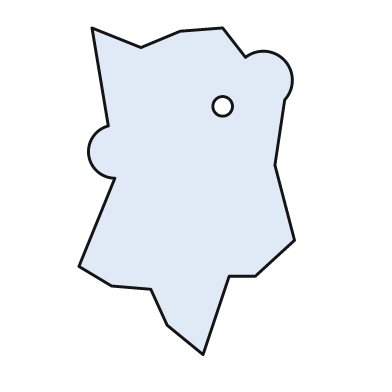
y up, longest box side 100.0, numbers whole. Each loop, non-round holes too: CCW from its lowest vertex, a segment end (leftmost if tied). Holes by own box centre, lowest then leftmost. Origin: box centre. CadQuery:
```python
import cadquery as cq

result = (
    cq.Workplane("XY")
    .moveTo(5.0, -50.0)
    .lineTo(13.0, -26.0)
    .lineTo(21.0, -26.0)
    .lineTo(33.0, -15.0)
    .lineTo(27.0, 8.0)
    .lineTo(30.0, 28.0)
    .threePointArc((30.0, 40.0), (18.0, 41.0))
    .lineTo(11.0, 50.0)
    .lineTo(-2.0, 49.0)
    .lineTo(-14.0, 44.0)
    .lineTo(-29.0, 50.0)
    .lineTo(-24.0, 20.0)
    .threePointArc((-30.0, 11.0), (-22.0, 4.0))
    .lineTo(-33.0, -23.0)
    .lineTo(-23.0, -29.0)
    .lineTo(-11.0, -30.0)
    .lineTo(-6.0, -41.0)
    .close()
    .moveTo(11.0, 26.0)
    .circle(3.0)
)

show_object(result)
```